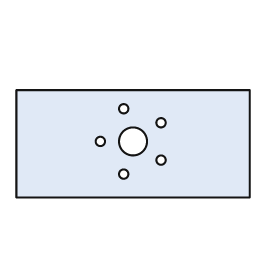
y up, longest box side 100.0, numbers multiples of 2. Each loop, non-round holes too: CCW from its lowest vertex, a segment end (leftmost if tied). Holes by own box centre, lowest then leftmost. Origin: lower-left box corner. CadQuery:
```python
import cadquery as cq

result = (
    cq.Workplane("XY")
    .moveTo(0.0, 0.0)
    .lineTo(100.0, 0.0)
    .lineTo(100.0, 46.0)
    .lineTo(0.0, 46.0)
    .close()
    .moveTo(46.0, 10.0)
    .circle(2.0)
    .moveTo(62.0, 16.0)
    .circle(2.0)
    .moveTo(36.0, 24.0)
    .circle(2.0)
    .moveTo(50.0, 24.0)
    .circle(6.0)
    .moveTo(62.0, 32.0)
    .circle(2.0)
    .moveTo(46.0, 38.0)
    .circle(2.0)
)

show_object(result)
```